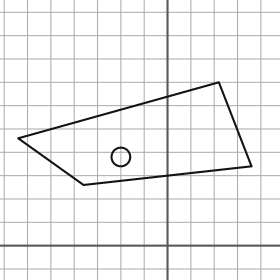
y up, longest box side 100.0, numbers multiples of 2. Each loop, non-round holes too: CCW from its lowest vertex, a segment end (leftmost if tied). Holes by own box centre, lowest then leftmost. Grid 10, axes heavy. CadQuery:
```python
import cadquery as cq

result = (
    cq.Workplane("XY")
    .moveTo(-36.0, 26.0)
    .lineTo(36.0, 34.0)
    .lineTo(22.0, 70.0)
    .lineTo(-64.0, 46.0)
    .close()
    .moveTo(-20.0, 38.0)
    .circle(4.0)
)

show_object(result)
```